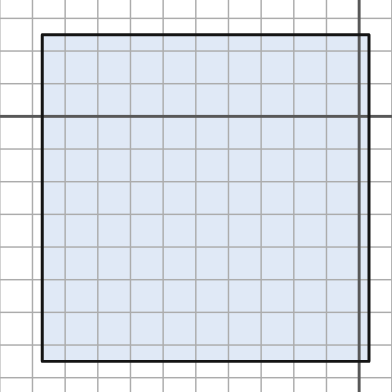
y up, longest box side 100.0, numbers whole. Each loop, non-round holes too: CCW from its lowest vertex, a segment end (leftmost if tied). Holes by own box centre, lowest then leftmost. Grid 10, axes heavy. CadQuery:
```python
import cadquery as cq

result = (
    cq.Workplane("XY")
    .moveTo(-97.0, -75.0)
    .lineTo(3.0, -75.0)
    .lineTo(3.0, 25.0)
    .lineTo(-97.0, 25.0)
    .close()
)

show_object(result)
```